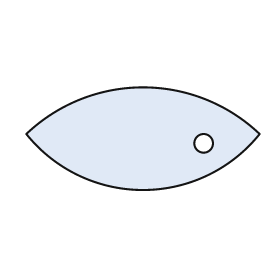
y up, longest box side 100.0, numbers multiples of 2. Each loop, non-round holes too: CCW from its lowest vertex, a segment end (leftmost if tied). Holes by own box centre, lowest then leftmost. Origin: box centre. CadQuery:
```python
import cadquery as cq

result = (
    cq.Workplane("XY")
    .moveTo(-50.0, 2.0)
    .threePointArc((0.0, -22.0), (50.0, 2.0))
    .threePointArc((0.0, 22.0), (-50.0, 2.0))
    .close()
    .moveTo(26.0, -2.0)
    .circle(4.0)
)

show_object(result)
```